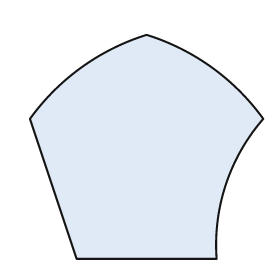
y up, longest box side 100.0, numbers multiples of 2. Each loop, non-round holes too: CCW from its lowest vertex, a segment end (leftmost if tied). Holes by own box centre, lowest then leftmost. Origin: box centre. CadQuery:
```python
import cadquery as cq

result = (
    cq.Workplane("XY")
    .moveTo(-30.0, -48.0)
    .lineTo(30.0, -48.0)
    .threePointArc((34.0, -16.0), (50.0, 12.0))
    .threePointArc((28.0, 34.0), (0.0, 48.0))
    .threePointArc((-28.0, 34.0), (-50.0, 12.0))
    .close()
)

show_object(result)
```